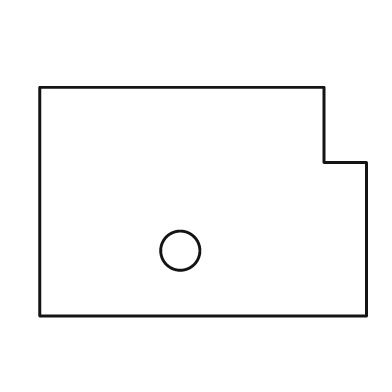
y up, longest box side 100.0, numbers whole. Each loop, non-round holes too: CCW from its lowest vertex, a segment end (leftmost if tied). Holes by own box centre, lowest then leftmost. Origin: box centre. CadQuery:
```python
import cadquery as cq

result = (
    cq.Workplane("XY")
    .moveTo(-50.0, -35.0)
    .lineTo(50.0, -35.0)
    .lineTo(50.0, 12.0)
    .lineTo(37.0, 12.0)
    .lineTo(37.0, 35.0)
    .lineTo(-50.0, 35.0)
    .close()
    .moveTo(-7.0, -15.0)
    .circle(6.0)
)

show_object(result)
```